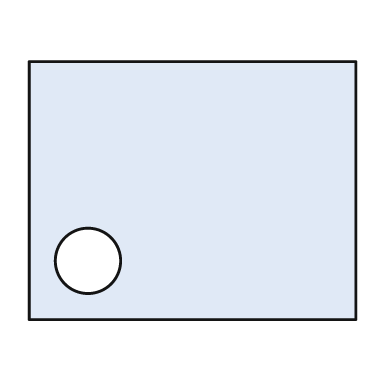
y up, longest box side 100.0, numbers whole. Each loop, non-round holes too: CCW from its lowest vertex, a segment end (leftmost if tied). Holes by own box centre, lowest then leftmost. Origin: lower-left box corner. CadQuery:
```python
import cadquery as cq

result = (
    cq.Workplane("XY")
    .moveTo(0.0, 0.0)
    .lineTo(100.0, 0.0)
    .lineTo(100.0, 79.0)
    .lineTo(0.0, 79.0)
    .close()
    .moveTo(18.0, 18.0)
    .circle(10.0)
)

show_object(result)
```